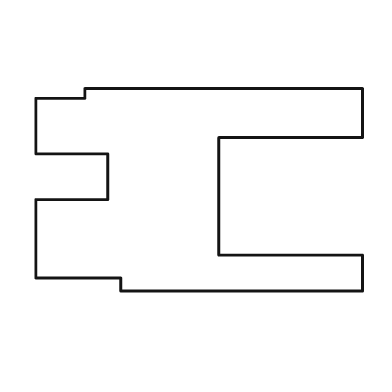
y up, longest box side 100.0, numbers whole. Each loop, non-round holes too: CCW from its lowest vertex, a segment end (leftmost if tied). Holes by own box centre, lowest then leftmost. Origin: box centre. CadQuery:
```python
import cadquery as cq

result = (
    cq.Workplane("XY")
    .moveTo(-24.0, -31.0)
    .lineTo(50.0, -31.0)
    .lineTo(50.0, -20.0)
    .lineTo(6.0, -20.0)
    .lineTo(6.0, 16.0)
    .lineTo(50.0, 16.0)
    .lineTo(50.0, 31.0)
    .lineTo(-35.0, 31.0)
    .lineTo(-35.0, 28.0)
    .lineTo(-50.0, 28.0)
    .lineTo(-50.0, 11.0)
    .lineTo(-28.0, 11.0)
    .lineTo(-28.0, -3.0)
    .lineTo(-50.0, -3.0)
    .lineTo(-50.0, -27.0)
    .lineTo(-24.0, -27.0)
    .close()
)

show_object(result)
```